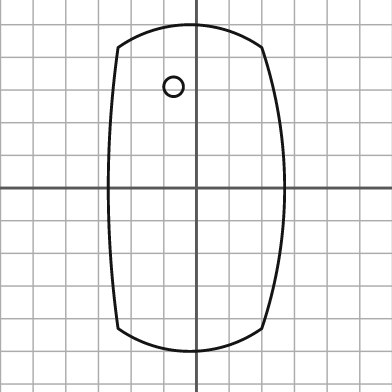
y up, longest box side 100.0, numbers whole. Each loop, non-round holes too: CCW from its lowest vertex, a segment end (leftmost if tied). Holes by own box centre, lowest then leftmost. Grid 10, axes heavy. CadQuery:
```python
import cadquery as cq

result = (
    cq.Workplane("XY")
    .moveTo(-24.0, -43.0)
    .threePointArc((-2.0, -50.0), (20.0, -43.0))
    .threePointArc((27.0, 0.0), (20.0, 43.0))
    .threePointArc((-2.0, 50.0), (-24.0, 43.0))
    .threePointArc((-27.0, 0.0), (-24.0, -43.0))
    .close()
    .moveTo(-7.0, 31.0)
    .circle(3.0)
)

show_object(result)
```